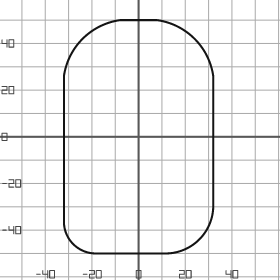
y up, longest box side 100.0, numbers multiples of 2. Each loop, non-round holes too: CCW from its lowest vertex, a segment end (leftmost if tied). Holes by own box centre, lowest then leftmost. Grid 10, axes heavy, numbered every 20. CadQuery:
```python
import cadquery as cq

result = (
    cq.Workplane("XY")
    .moveTo(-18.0, -50.0)
    .lineTo(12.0, -50.0)
    .threePointArc((26.0, -44.0), (32.0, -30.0))
    .lineTo(32.0, 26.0)
    .threePointArc((24.0, 42.0), (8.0, 50.0))
    .lineTo(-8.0, 50.0)
    .threePointArc((-24.0, 42.0), (-32.0, 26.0))
    .lineTo(-32.0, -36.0)
    .threePointArc((-28.0, -46.0), (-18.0, -50.0))
    .close()
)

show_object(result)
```